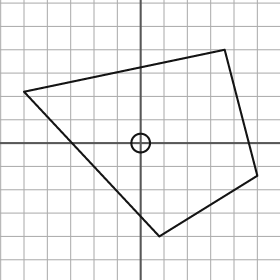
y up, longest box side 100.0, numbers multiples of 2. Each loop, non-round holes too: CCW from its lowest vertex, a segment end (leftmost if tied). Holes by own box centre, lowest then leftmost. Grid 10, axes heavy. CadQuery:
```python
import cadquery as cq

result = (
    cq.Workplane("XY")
    .moveTo(8.0, -40.0)
    .lineTo(50.0, -14.0)
    .lineTo(36.0, 40.0)
    .lineTo(-50.0, 22.0)
    .close()
    .moveTo(0.0, 0.0)
    .circle(4.0)
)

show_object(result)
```